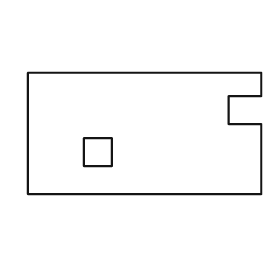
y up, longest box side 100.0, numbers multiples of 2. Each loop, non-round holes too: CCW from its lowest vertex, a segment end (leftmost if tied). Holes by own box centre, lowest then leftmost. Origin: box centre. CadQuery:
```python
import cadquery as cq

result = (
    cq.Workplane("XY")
    .moveTo(-50.0, -26.0)
    .lineTo(50.0, -26.0)
    .lineTo(50.0, 4.0)
    .lineTo(36.0, 4.0)
    .lineTo(36.0, 16.0)
    .lineTo(50.0, 16.0)
    .lineTo(50.0, 26.0)
    .lineTo(-50.0, 26.0)
    .close()
    .moveTo(-26.0, -14.0)
    .lineTo(-14.0, -14.0)
    .lineTo(-14.0, -2.0)
    .lineTo(-26.0, -2.0)
    .close()
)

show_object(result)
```